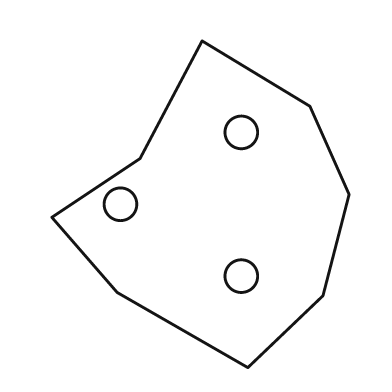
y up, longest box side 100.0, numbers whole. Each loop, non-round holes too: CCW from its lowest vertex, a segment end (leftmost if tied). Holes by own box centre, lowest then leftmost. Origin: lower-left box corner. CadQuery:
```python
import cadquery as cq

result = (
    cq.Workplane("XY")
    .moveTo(60.0, 0.0)
    .lineTo(83.0, 22.0)
    .lineTo(91.0, 53.0)
    .lineTo(79.0, 80.0)
    .lineTo(46.0, 100.0)
    .lineTo(27.0, 64.0)
    .lineTo(0.0, 46.0)
    .lineTo(20.0, 23.0)
    .close()
    .moveTo(58.0, 28.0)
    .circle(5.0)
    .moveTo(21.0, 50.0)
    .circle(5.0)
    .moveTo(58.0, 72.0)
    .circle(5.0)
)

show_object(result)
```